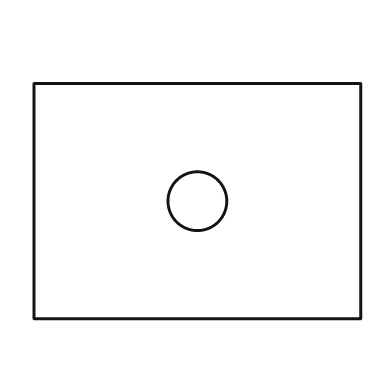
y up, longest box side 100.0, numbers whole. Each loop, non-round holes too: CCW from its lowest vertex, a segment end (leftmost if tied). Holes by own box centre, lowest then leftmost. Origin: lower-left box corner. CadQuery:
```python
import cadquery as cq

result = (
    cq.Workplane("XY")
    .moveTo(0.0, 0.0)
    .lineTo(100.0, 0.0)
    .lineTo(100.0, 72.0)
    .lineTo(0.0, 72.0)
    .close()
    .moveTo(50.0, 36.0)
    .circle(9.0)
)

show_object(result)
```